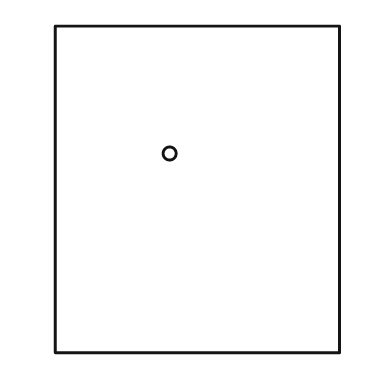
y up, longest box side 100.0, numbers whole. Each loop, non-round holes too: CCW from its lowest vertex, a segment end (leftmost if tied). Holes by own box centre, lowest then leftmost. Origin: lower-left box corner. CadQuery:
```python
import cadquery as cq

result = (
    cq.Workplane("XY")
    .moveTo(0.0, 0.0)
    .lineTo(87.0, 0.0)
    .lineTo(87.0, 100.0)
    .lineTo(0.0, 100.0)
    .close()
    .moveTo(35.0, 61.0)
    .circle(2.0)
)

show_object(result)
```